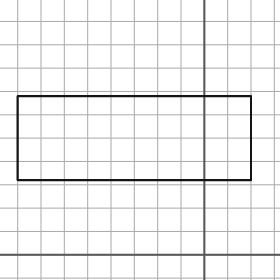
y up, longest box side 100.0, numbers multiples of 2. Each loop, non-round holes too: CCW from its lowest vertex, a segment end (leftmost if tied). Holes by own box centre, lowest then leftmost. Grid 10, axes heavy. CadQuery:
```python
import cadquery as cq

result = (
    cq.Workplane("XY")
    .moveTo(-80.0, 32.0)
    .lineTo(20.0, 32.0)
    .lineTo(20.0, 68.0)
    .lineTo(-80.0, 68.0)
    .close()
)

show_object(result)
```